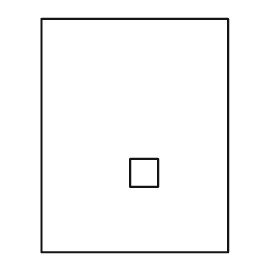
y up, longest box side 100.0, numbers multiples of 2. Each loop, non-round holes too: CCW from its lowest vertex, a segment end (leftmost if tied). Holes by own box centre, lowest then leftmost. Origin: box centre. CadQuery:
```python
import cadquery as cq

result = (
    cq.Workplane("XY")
    .moveTo(-40.0, -50.0)
    .lineTo(40.0, -50.0)
    .lineTo(40.0, 50.0)
    .lineTo(-40.0, 50.0)
    .close()
    .moveTo(-2.0, -22.0)
    .lineTo(10.0, -22.0)
    .lineTo(10.0, -10.0)
    .lineTo(-2.0, -10.0)
    .close()
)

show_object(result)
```